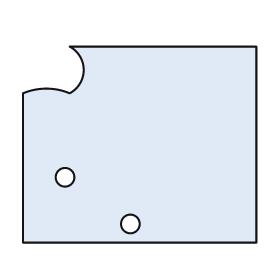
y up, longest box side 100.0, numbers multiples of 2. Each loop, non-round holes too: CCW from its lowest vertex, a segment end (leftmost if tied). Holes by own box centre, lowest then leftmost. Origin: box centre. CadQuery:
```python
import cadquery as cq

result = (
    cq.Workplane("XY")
    .moveTo(-50.0, -42.0)
    .lineTo(50.0, -42.0)
    .lineTo(50.0, 42.0)
    .lineTo(-30.0, 42.0)
    .threePointArc((-24.0, 32.0), (-30.0, 22.0))
    .threePointArc((-40.0, 24.0), (-50.0, 22.0))
    .close()
    .moveTo(-4.0, -34.0)
    .circle(4.0)
    .moveTo(-32.0, -14.0)
    .circle(4.0)
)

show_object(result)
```